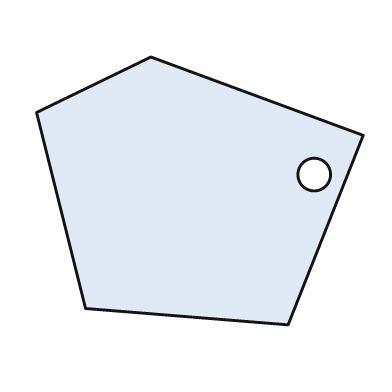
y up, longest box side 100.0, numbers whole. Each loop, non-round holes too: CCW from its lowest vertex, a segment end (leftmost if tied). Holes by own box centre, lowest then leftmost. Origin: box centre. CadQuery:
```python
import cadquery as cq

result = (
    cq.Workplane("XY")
    .moveTo(27.0, -41.0)
    .lineTo(50.0, 17.0)
    .lineTo(-15.0, 41.0)
    .lineTo(-50.0, 24.0)
    .lineTo(-35.0, -36.0)
    .close()
    .moveTo(35.0, 5.0)
    .circle(5.0)
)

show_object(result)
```